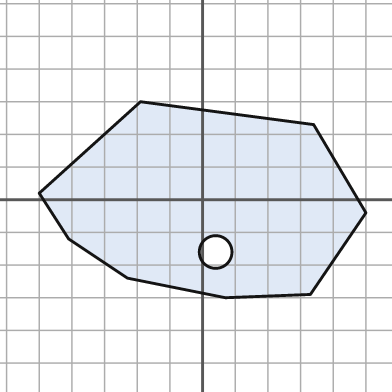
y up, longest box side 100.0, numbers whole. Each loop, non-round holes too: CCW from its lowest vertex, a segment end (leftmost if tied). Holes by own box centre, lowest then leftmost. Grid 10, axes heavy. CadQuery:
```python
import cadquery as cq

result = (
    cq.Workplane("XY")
    .moveTo(7.0, -30.0)
    .lineTo(33.0, -29.0)
    .lineTo(50.0, -4.0)
    .lineTo(34.0, 23.0)
    .lineTo(-19.0, 30.0)
    .lineTo(-50.0, 2.0)
    .lineTo(-41.0, -12.0)
    .lineTo(-23.0, -24.0)
    .close()
    .moveTo(4.0, -16.0)
    .circle(5.0)
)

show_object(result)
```